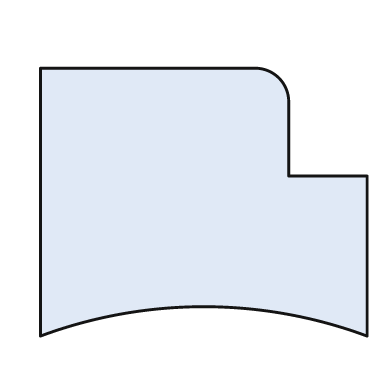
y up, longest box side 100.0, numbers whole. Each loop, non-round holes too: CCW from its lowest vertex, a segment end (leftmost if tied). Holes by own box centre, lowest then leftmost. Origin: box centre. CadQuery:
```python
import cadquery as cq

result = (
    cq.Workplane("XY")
    .moveTo(-50.0, -41.0)
    .threePointArc((0.0, -32.0), (50.0, -41.0))
    .lineTo(50.0, 8.0)
    .lineTo(26.0, 8.0)
    .lineTo(26.0, 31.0)
    .threePointArc((23.0, 38.0), (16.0, 41.0))
    .lineTo(-50.0, 41.0)
    .close()
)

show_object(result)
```